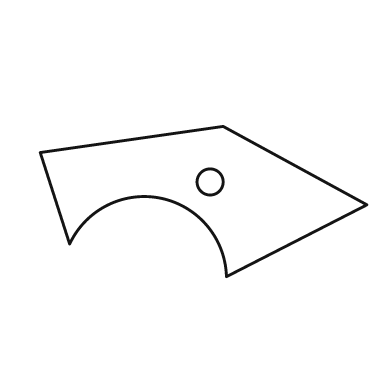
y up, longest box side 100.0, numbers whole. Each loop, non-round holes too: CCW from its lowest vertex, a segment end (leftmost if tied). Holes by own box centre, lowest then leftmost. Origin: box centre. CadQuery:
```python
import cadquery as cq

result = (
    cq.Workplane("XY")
    .moveTo(7.0, -23.0)
    .lineTo(50.0, -1.0)
    .lineTo(6.0, 23.0)
    .lineTo(-50.0, 15.0)
    .lineTo(-41.0, -13.0)
    .threePointArc((-13.0, 1.0), (7.0, -23.0))
    .close()
    .moveTo(2.0, 6.0)
    .circle(4.0)
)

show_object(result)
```